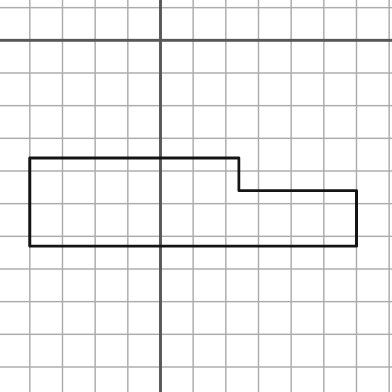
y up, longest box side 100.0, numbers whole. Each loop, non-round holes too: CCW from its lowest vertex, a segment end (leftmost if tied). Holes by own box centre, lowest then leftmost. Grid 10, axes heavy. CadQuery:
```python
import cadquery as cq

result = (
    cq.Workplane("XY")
    .moveTo(-40.0, -63.0)
    .lineTo(60.0, -63.0)
    .lineTo(60.0, -46.0)
    .lineTo(24.0, -46.0)
    .lineTo(24.0, -36.0)
    .lineTo(-40.0, -36.0)
    .close()
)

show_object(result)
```